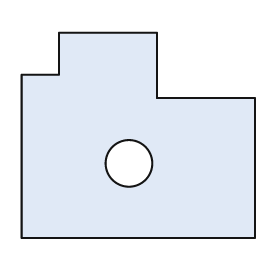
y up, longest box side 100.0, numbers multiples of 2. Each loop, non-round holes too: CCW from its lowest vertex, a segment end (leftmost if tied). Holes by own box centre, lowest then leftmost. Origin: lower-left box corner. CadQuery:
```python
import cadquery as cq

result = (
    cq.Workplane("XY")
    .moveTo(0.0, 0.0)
    .lineTo(100.0, 0.0)
    .lineTo(100.0, 60.0)
    .lineTo(58.0, 60.0)
    .lineTo(58.0, 88.0)
    .lineTo(16.0, 88.0)
    .lineTo(16.0, 70.0)
    .lineTo(0.0, 70.0)
    .close()
    .moveTo(46.0, 32.0)
    .circle(10.0)
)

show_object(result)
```